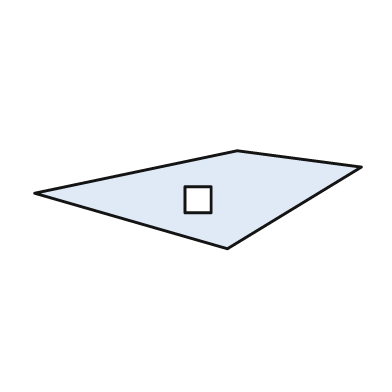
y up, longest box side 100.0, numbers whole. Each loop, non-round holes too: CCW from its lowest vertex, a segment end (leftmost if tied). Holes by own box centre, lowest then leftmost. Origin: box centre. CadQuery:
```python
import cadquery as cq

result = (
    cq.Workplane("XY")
    .moveTo(9.0, -15.0)
    .lineTo(50.0, 10.0)
    .lineTo(12.0, 15.0)
    .lineTo(-50.0, 2.0)
    .close()
    .moveTo(-4.0, -4.0)
    .lineTo(4.0, -4.0)
    .lineTo(4.0, 4.0)
    .lineTo(-4.0, 4.0)
    .close()
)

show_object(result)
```